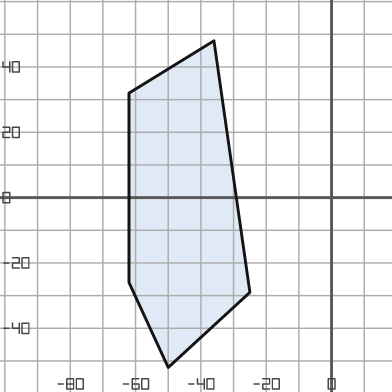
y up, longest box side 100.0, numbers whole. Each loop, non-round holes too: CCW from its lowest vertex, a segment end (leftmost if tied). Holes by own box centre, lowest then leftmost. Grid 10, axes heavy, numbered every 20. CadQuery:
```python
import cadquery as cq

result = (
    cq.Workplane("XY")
    .moveTo(-50.0, -52.0)
    .lineTo(-25.0, -29.0)
    .lineTo(-36.0, 48.0)
    .lineTo(-62.0, 32.0)
    .lineTo(-62.0, -26.0)
    .close()
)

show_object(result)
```